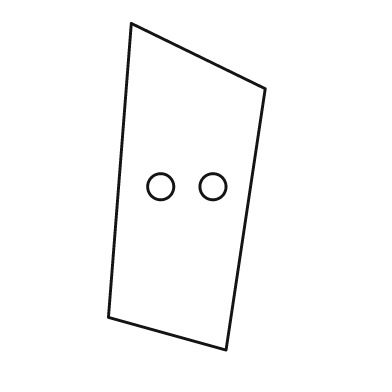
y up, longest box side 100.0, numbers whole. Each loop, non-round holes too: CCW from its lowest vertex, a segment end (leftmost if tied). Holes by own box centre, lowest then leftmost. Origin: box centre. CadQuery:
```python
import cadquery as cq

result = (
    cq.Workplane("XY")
    .moveTo(12.0, -50.0)
    .lineTo(24.0, 30.0)
    .lineTo(-17.0, 50.0)
    .lineTo(-24.0, -40.0)
    .close()
    .moveTo(-8.0, 0.0)
    .circle(4.0)
    .moveTo(8.0, 0.0)
    .circle(4.0)
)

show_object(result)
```